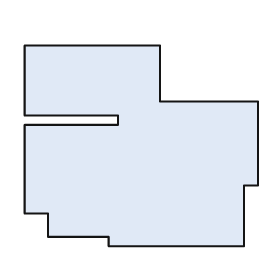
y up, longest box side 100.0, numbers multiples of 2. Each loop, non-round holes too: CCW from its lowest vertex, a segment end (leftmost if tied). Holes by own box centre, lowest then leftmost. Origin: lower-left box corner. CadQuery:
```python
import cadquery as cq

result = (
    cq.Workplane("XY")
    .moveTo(36.0, 0.0)
    .lineTo(94.0, 0.0)
    .lineTo(94.0, 26.0)
    .lineTo(100.0, 26.0)
    .lineTo(100.0, 62.0)
    .lineTo(58.0, 62.0)
    .lineTo(58.0, 86.0)
    .lineTo(0.0, 86.0)
    .lineTo(0.0, 56.0)
    .lineTo(40.0, 56.0)
    .lineTo(40.0, 52.0)
    .lineTo(0.0, 52.0)
    .lineTo(0.0, 14.0)
    .lineTo(10.0, 14.0)
    .lineTo(10.0, 4.0)
    .lineTo(36.0, 4.0)
    .close()
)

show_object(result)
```